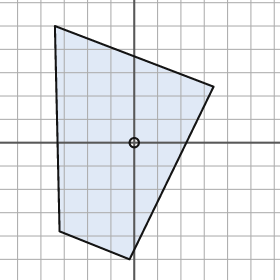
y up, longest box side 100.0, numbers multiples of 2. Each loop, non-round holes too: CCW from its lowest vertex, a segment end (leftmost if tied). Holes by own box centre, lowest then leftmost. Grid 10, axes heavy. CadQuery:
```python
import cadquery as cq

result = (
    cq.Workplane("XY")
    .moveTo(-2.0, -50.0)
    .lineTo(34.0, 24.0)
    .lineTo(-34.0, 50.0)
    .lineTo(-32.0, -38.0)
    .close()
    .moveTo(0.0, 0.0)
    .circle(2.0)
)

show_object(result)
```